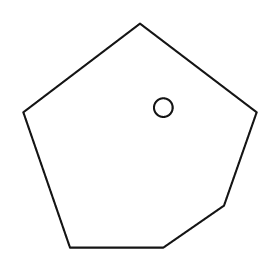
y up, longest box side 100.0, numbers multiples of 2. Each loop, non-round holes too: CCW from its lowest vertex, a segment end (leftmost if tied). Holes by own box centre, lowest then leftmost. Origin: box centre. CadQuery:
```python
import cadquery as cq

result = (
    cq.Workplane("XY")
    .moveTo(-30.0, -48.0)
    .lineTo(10.0, -48.0)
    .lineTo(36.0, -30.0)
    .lineTo(50.0, 10.0)
    .lineTo(0.0, 48.0)
    .lineTo(-50.0, 10.0)
    .close()
    .moveTo(10.0, 12.0)
    .circle(4.0)
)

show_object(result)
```